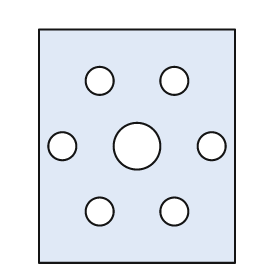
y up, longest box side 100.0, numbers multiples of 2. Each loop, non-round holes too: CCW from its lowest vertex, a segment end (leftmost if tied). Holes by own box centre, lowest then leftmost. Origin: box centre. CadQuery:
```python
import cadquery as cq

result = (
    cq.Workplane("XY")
    .moveTo(-42.0, -50.0)
    .lineTo(42.0, -50.0)
    .lineTo(42.0, 50.0)
    .lineTo(-42.0, 50.0)
    .close()
    .moveTo(-16.0, -28.0)
    .circle(6.0)
    .moveTo(16.0, -28.0)
    .circle(6.0)
    .moveTo(-32.0, 0.0)
    .circle(6.0)
    .moveTo(0.0, 0.0)
    .circle(10.0)
    .moveTo(32.0, 0.0)
    .circle(6.0)
    .moveTo(-16.0, 28.0)
    .circle(6.0)
    .moveTo(16.0, 28.0)
    .circle(6.0)
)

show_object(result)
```